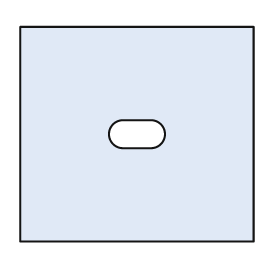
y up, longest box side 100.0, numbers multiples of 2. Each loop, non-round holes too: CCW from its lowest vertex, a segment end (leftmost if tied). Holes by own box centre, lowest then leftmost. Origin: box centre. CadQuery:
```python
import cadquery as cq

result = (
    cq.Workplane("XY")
    .moveTo(-50.0, -46.0)
    .lineTo(50.0, -46.0)
    .lineTo(50.0, 46.0)
    .lineTo(-50.0, 46.0)
    .close()
    .moveTo(-6.0, -6.0)
    .lineTo(6.0, -6.0)
    .threePointArc((12.0, 0.0), (6.0, 6.0))
    .lineTo(-6.0, 6.0)
    .threePointArc((-12.0, 0.0), (-6.0, -6.0))
    .close()
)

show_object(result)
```